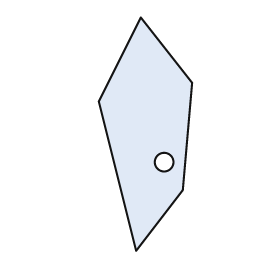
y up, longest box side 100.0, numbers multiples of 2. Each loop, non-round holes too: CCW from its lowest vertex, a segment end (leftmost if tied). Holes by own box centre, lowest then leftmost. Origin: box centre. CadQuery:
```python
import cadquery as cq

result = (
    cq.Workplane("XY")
    .moveTo(-4.0, -50.0)
    .lineTo(16.0, -24.0)
    .lineTo(20.0, 22.0)
    .lineTo(-2.0, 50.0)
    .lineTo(-20.0, 14.0)
    .close()
    .moveTo(8.0, -12.0)
    .circle(4.0)
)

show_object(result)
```